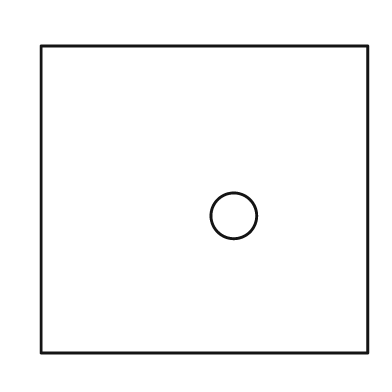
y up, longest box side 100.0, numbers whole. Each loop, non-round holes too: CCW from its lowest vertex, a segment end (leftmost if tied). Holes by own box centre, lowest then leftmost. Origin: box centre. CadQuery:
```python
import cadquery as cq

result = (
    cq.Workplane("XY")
    .moveTo(-50.0, -47.0)
    .lineTo(50.0, -47.0)
    .lineTo(50.0, 47.0)
    .lineTo(-50.0, 47.0)
    .close()
    .moveTo(9.0, -5.0)
    .circle(7.0)
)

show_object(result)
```